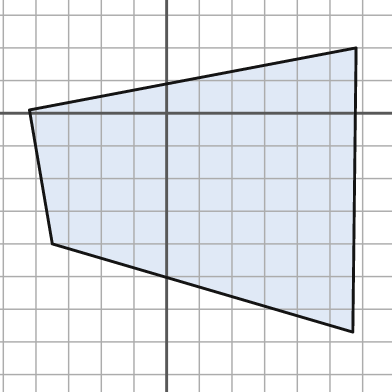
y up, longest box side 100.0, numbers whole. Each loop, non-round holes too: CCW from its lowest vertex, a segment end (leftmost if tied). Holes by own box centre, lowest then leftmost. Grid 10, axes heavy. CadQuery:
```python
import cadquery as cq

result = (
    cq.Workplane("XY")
    .moveTo(57.0, -67.0)
    .lineTo(58.0, 20.0)
    .lineTo(-42.0, 1.0)
    .lineTo(-35.0, -40.0)
    .close()
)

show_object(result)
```